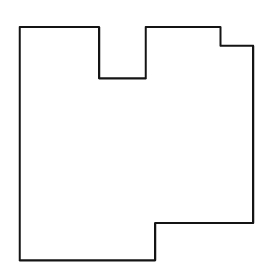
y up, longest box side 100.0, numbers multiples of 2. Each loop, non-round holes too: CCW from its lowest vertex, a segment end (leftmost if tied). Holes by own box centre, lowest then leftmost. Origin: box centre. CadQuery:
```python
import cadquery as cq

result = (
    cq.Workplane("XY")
    .moveTo(-50.0, -50.0)
    .lineTo(8.0, -50.0)
    .lineTo(8.0, -34.0)
    .lineTo(50.0, -34.0)
    .lineTo(50.0, 42.0)
    .lineTo(36.0, 42.0)
    .lineTo(36.0, 50.0)
    .lineTo(4.0, 50.0)
    .lineTo(4.0, 28.0)
    .lineTo(-16.0, 28.0)
    .lineTo(-16.0, 50.0)
    .lineTo(-50.0, 50.0)
    .close()
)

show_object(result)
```